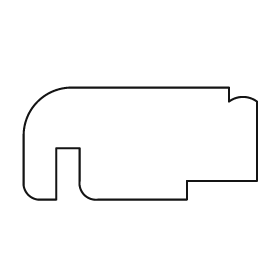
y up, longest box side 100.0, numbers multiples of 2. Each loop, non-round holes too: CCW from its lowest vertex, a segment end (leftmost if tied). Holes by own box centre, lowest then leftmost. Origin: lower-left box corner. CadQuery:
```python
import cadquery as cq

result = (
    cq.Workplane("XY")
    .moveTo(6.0, 0.0)
    .lineTo(14.0, 0.0)
    .lineTo(14.0, 22.0)
    .lineTo(24.0, 22.0)
    .lineTo(24.0, 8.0)
    .threePointArc((26.0, 2.0), (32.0, 0.0))
    .lineTo(70.0, 0.0)
    .lineTo(70.0, 8.0)
    .lineTo(100.0, 8.0)
    .lineTo(100.0, 42.0)
    .threePointArc((94.0, 44.0), (88.0, 42.0))
    .lineTo(88.0, 48.0)
    .lineTo(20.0, 48.0)
    .threePointArc((6.0, 42.0), (0.0, 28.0))
    .lineTo(0.0, 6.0)
    .threePointArc((2.0, 2.0), (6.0, 0.0))
    .close()
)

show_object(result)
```